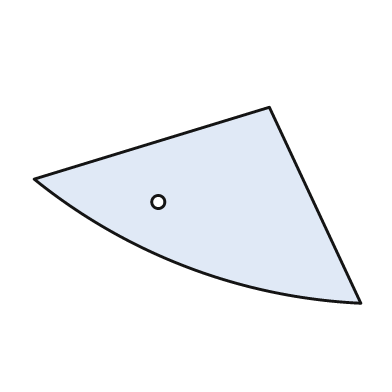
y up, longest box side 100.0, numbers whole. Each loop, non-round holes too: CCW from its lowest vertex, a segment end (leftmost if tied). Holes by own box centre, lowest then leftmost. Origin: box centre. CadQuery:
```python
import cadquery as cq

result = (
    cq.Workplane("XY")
    .moveTo(50.0, -30.0)
    .lineTo(22.0, 30.0)
    .lineTo(-50.0, 8.0)
    .threePointArc((-3.0, -19.0), (50.0, -30.0))
    .close()
    .moveTo(-12.0, 1.0)
    .circle(2.0)
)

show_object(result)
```